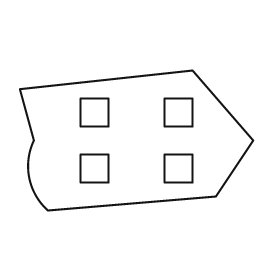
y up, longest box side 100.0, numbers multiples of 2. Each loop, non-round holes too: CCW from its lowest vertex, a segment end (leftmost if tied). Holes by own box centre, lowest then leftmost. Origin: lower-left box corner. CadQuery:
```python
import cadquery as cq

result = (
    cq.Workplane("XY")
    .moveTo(12.0, 0.0)
    .lineTo(84.0, 6.0)
    .lineTo(100.0, 30.0)
    .lineTo(74.0, 60.0)
    .lineTo(0.0, 52.0)
    .lineTo(6.0, 30.0)
    .threePointArc((4.0, 14.0), (12.0, 0.0))
    .close()
    .moveTo(26.0, 12.0)
    .lineTo(38.0, 12.0)
    .lineTo(38.0, 24.0)
    .lineTo(26.0, 24.0)
    .close()
    .moveTo(62.0, 12.0)
    .lineTo(74.0, 12.0)
    .lineTo(74.0, 24.0)
    .lineTo(62.0, 24.0)
    .close()
    .moveTo(26.0, 36.0)
    .lineTo(38.0, 36.0)
    .lineTo(38.0, 48.0)
    .lineTo(26.0, 48.0)
    .close()
    .moveTo(62.0, 36.0)
    .lineTo(74.0, 36.0)
    .lineTo(74.0, 48.0)
    .lineTo(62.0, 48.0)
    .close()
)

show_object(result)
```